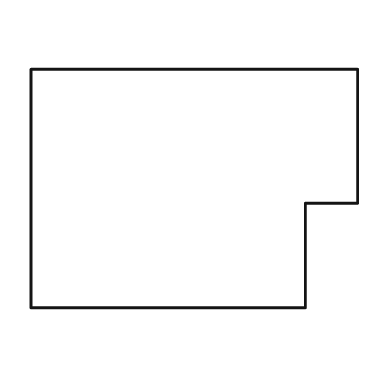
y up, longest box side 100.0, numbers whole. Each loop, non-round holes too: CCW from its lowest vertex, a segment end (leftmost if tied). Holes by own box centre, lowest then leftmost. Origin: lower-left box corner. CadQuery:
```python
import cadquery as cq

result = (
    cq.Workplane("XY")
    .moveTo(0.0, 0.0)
    .lineTo(84.0, 0.0)
    .lineTo(84.0, 32.0)
    .lineTo(100.0, 32.0)
    .lineTo(100.0, 73.0)
    .lineTo(0.0, 73.0)
    .close()
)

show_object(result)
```